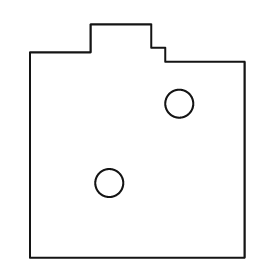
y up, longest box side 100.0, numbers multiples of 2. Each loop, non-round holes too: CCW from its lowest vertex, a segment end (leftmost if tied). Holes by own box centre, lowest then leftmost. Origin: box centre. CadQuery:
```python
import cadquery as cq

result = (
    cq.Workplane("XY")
    .moveTo(-46.0, -50.0)
    .lineTo(46.0, -50.0)
    .lineTo(46.0, 34.0)
    .lineTo(12.0, 34.0)
    .lineTo(12.0, 40.0)
    .lineTo(6.0, 40.0)
    .lineTo(6.0, 50.0)
    .lineTo(-20.0, 50.0)
    .lineTo(-20.0, 38.0)
    .lineTo(-46.0, 38.0)
    .close()
    .moveTo(-12.0, -18.0)
    .circle(6.0)
    .moveTo(18.0, 16.0)
    .circle(6.0)
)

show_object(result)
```